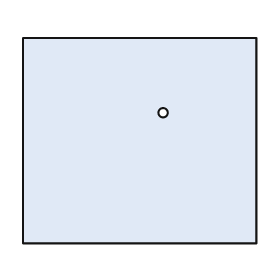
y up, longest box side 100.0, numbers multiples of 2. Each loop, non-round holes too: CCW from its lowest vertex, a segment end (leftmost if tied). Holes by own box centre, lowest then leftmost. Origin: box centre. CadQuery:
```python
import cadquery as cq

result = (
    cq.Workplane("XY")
    .moveTo(-50.0, -44.0)
    .lineTo(50.0, -44.0)
    .lineTo(50.0, 44.0)
    .lineTo(-50.0, 44.0)
    .close()
    .moveTo(10.0, 12.0)
    .circle(2.0)
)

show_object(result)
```